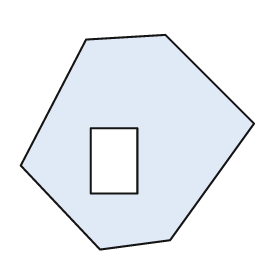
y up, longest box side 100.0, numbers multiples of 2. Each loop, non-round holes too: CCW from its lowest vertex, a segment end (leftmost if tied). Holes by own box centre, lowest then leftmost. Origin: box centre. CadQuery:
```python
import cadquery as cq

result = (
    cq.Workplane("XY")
    .moveTo(-16.0, -46.0)
    .lineTo(14.0, -42.0)
    .lineTo(50.0, 8.0)
    .lineTo(12.0, 46.0)
    .lineTo(-22.0, 44.0)
    .lineTo(-50.0, -10.0)
    .close()
    .moveTo(-20.0, -22.0)
    .lineTo(0.0, -22.0)
    .lineTo(0.0, 6.0)
    .lineTo(-20.0, 6.0)
    .close()
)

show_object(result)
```